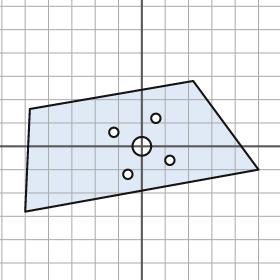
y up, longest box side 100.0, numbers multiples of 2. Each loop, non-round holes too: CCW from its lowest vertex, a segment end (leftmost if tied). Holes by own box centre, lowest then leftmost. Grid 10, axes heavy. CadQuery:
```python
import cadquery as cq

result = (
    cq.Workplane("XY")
    .moveTo(-50.0, -28.0)
    .lineTo(50.0, -10.0)
    .lineTo(22.0, 28.0)
    .lineTo(-48.0, 16.0)
    .close()
    .moveTo(-6.0, -12.0)
    .circle(2.0)
    .moveTo(12.0, -6.0)
    .circle(2.0)
    .moveTo(0.0, 0.0)
    .circle(4.0)
    .moveTo(-12.0, 6.0)
    .circle(2.0)
    .moveTo(6.0, 12.0)
    .circle(2.0)
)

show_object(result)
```